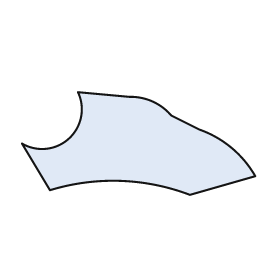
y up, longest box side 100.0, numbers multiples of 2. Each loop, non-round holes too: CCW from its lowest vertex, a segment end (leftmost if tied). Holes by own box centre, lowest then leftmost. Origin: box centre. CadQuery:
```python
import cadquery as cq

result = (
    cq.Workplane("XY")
    .moveTo(22.0, -22.0)
    .lineTo(50.0, -14.0)
    .threePointArc((40.0, -2.0), (26.0, 6.0))
    .lineTo(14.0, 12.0)
    .threePointArc((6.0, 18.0), (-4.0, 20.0))
    .lineTo(-26.0, 22.0)
    .threePointArc((-30.0, 2.0), (-50.0, 0.0))
    .lineTo(-38.0, -20.0)
    .threePointArc((-8.0, -16.0), (22.0, -22.0))
    .close()
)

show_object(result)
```